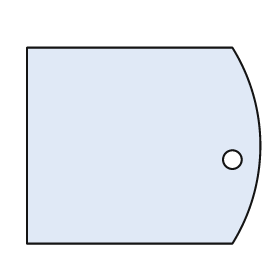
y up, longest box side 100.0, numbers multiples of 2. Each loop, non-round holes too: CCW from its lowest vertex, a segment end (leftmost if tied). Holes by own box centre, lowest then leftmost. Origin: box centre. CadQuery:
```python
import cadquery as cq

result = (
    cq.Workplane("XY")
    .moveTo(-50.0, -42.0)
    .lineTo(38.0, -42.0)
    .threePointArc((50.0, 0.0), (38.0, 42.0))
    .lineTo(-50.0, 42.0)
    .close()
    .moveTo(38.0, -6.0)
    .circle(4.0)
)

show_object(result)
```